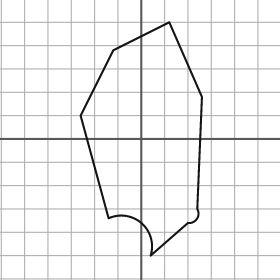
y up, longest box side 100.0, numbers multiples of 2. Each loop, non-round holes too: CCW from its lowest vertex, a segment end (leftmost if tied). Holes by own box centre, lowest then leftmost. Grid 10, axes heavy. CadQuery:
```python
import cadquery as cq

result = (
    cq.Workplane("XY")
    .moveTo(4.0, -50.0)
    .lineTo(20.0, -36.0)
    .threePointArc((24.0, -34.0), (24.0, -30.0))
    .lineTo(26.0, 18.0)
    .lineTo(12.0, 50.0)
    .lineTo(-12.0, 38.0)
    .lineTo(-26.0, 10.0)
    .lineTo(-14.0, -34.0)
    .threePointArc((0.0, -36.0), (4.0, -50.0))
    .close()
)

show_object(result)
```